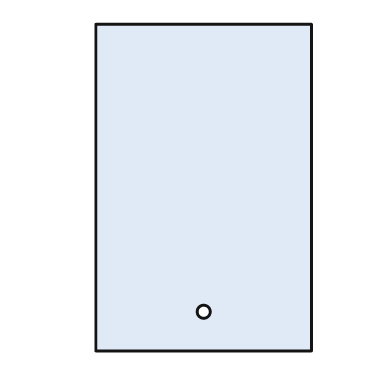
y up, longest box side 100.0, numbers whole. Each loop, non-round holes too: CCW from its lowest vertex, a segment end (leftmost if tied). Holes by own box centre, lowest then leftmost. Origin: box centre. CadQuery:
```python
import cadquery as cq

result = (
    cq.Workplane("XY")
    .moveTo(-33.0, -50.0)
    .lineTo(33.0, -50.0)
    .lineTo(33.0, 50.0)
    .lineTo(-33.0, 50.0)
    .close()
    .moveTo(0.0, -38.0)
    .circle(2.0)
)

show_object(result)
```